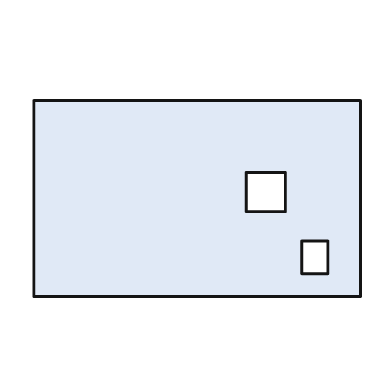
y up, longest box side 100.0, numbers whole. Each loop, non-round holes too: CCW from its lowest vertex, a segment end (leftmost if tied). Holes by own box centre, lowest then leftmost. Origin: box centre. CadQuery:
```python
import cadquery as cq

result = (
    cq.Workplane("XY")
    .moveTo(-50.0, -30.0)
    .lineTo(50.0, -30.0)
    .lineTo(50.0, 30.0)
    .lineTo(-50.0, 30.0)
    .close()
    .moveTo(32.0, -23.0)
    .lineTo(40.0, -23.0)
    .lineTo(40.0, -13.0)
    .lineTo(32.0, -13.0)
    .close()
    .moveTo(15.0, -4.0)
    .lineTo(27.0, -4.0)
    .lineTo(27.0, 8.0)
    .lineTo(15.0, 8.0)
    .close()
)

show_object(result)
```